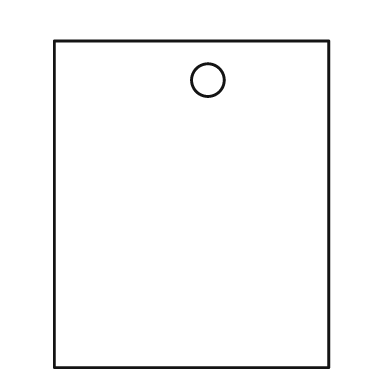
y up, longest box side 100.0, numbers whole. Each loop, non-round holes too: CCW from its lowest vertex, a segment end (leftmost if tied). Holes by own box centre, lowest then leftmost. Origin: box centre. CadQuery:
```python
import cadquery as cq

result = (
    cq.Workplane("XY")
    .moveTo(-42.0, -50.0)
    .lineTo(42.0, -50.0)
    .lineTo(42.0, 50.0)
    .lineTo(-42.0, 50.0)
    .close()
    .moveTo(5.0, 38.0)
    .circle(5.0)
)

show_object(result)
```